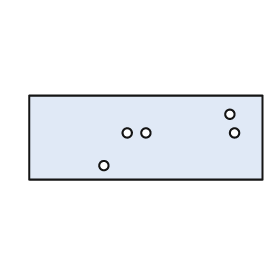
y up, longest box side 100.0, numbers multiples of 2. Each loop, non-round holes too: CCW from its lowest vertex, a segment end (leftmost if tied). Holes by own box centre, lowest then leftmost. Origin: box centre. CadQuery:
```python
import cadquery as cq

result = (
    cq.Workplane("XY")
    .moveTo(-50.0, -18.0)
    .lineTo(50.0, -18.0)
    .lineTo(50.0, 18.0)
    .lineTo(-50.0, 18.0)
    .close()
    .moveTo(-18.0, -12.0)
    .circle(2.0)
    .moveTo(-8.0, 2.0)
    .circle(2.0)
    .moveTo(0.0, 2.0)
    .circle(2.0)
    .moveTo(38.0, 2.0)
    .circle(2.0)
    .moveTo(36.0, 10.0)
    .circle(2.0)
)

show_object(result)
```